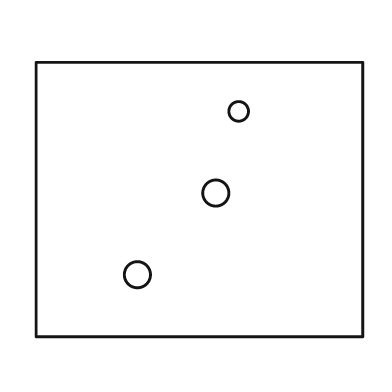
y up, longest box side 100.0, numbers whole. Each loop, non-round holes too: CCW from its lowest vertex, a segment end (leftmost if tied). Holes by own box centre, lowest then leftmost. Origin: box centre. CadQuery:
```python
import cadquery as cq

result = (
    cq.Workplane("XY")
    .moveTo(-50.0, -42.0)
    .lineTo(50.0, -42.0)
    .lineTo(50.0, 42.0)
    .lineTo(-50.0, 42.0)
    .close()
    .moveTo(-19.0, -23.0)
    .circle(4.0)
    .moveTo(5.0, 2.0)
    .circle(4.0)
    .moveTo(12.0, 27.0)
    .circle(3.0)
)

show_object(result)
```